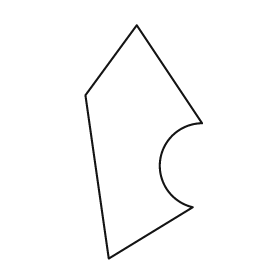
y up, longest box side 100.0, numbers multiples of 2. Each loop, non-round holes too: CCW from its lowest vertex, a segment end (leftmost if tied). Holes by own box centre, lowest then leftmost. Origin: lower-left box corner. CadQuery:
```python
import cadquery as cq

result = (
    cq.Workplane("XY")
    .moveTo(10.0, 0.0)
    .lineTo(46.0, 22.0)
    .threePointArc((32.0, 42.0), (50.0, 58.0))
    .lineTo(22.0, 100.0)
    .lineTo(0.0, 70.0)
    .close()
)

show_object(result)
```